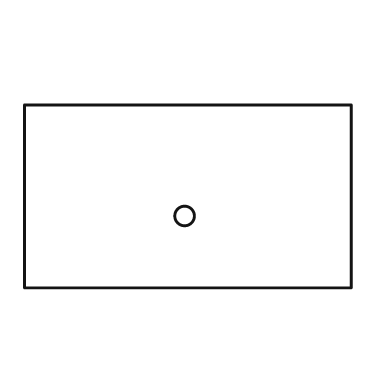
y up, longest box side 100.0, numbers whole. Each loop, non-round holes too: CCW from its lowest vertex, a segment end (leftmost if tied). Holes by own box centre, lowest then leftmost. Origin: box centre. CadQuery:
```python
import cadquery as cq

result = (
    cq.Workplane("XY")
    .moveTo(-50.0, -28.0)
    .lineTo(50.0, -28.0)
    .lineTo(50.0, 28.0)
    .lineTo(-50.0, 28.0)
    .close()
    .moveTo(-1.0, -6.0)
    .circle(3.0)
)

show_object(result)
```